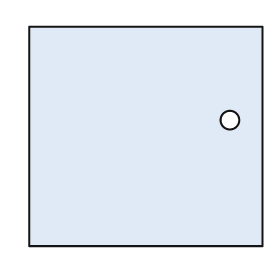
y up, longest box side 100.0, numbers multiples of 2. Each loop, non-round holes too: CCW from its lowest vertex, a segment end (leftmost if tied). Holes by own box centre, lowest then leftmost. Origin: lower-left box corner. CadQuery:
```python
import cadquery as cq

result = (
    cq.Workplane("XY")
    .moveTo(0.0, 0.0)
    .lineTo(100.0, 0.0)
    .lineTo(100.0, 94.0)
    .lineTo(0.0, 94.0)
    .close()
    .moveTo(86.0, 54.0)
    .circle(4.0)
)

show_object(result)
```